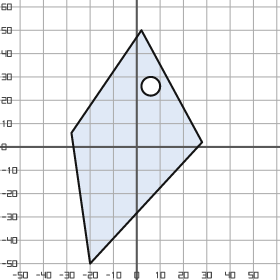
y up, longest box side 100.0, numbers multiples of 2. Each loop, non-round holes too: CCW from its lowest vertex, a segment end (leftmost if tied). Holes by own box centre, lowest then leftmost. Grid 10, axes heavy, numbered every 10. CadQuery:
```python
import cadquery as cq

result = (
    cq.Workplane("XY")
    .moveTo(-20.0, -50.0)
    .lineTo(28.0, 2.0)
    .lineTo(2.0, 50.0)
    .lineTo(-28.0, 6.0)
    .close()
    .moveTo(6.0, 26.0)
    .circle(4.0)
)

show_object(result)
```